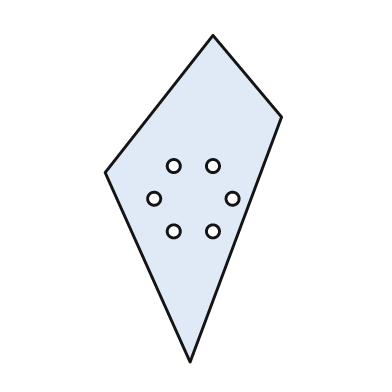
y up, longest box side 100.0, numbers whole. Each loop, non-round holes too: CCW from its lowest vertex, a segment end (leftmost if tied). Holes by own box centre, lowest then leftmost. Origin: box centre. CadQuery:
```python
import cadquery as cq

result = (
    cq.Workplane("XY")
    .moveTo(-1.0, -50.0)
    .lineTo(27.0, 25.0)
    .lineTo(6.0, 50.0)
    .lineTo(-27.0, 8.0)
    .close()
    .moveTo(-6.0, -10.0)
    .circle(2.0)
    .moveTo(6.0, -10.0)
    .circle(2.0)
    .moveTo(-12.0, 0.0)
    .circle(2.0)
    .moveTo(12.0, 0.0)
    .circle(2.0)
    .moveTo(-6.0, 10.0)
    .circle(2.0)
    .moveTo(6.0, 10.0)
    .circle(2.0)
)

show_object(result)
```